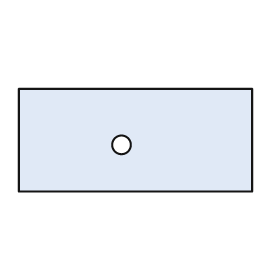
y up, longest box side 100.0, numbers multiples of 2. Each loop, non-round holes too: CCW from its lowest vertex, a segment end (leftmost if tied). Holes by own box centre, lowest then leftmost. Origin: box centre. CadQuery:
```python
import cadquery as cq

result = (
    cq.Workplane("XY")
    .moveTo(-50.0, -22.0)
    .lineTo(50.0, -22.0)
    .lineTo(50.0, 22.0)
    .lineTo(-50.0, 22.0)
    .close()
    .moveTo(-6.0, -2.0)
    .circle(4.0)
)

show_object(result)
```